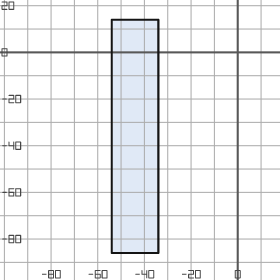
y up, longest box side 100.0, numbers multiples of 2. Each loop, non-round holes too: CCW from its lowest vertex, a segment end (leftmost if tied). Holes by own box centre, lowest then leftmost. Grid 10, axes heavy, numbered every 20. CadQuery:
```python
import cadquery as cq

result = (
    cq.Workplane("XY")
    .moveTo(-54.0, -86.0)
    .lineTo(-34.0, -86.0)
    .lineTo(-34.0, 14.0)
    .lineTo(-54.0, 14.0)
    .close()
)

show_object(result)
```